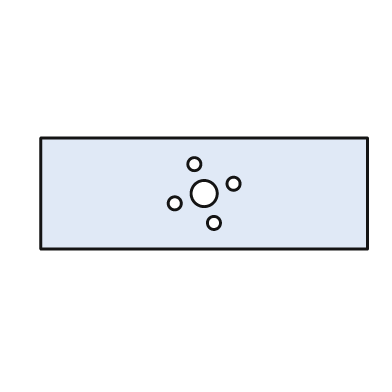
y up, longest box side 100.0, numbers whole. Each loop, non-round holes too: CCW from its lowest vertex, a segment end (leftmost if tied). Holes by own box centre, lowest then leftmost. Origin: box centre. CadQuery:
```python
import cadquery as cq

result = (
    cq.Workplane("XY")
    .moveTo(-50.0, -17.0)
    .lineTo(50.0, -17.0)
    .lineTo(50.0, 17.0)
    .lineTo(-50.0, 17.0)
    .close()
    .moveTo(3.0, -9.0)
    .circle(2.0)
    .moveTo(-9.0, -3.0)
    .circle(2.0)
    .moveTo(0.0, 0.0)
    .circle(4.0)
    .moveTo(9.0, 3.0)
    .circle(2.0)
    .moveTo(-3.0, 9.0)
    .circle(2.0)
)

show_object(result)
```